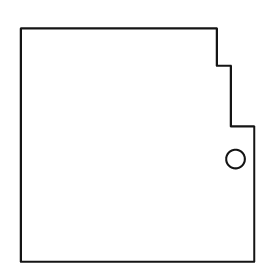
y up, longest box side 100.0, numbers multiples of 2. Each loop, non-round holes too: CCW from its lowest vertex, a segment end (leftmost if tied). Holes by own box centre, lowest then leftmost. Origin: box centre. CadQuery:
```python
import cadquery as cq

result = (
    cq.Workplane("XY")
    .moveTo(-50.0, -50.0)
    .lineTo(50.0, -50.0)
    .lineTo(50.0, 8.0)
    .lineTo(40.0, 8.0)
    .lineTo(40.0, 34.0)
    .lineTo(34.0, 34.0)
    .lineTo(34.0, 50.0)
    .lineTo(-50.0, 50.0)
    .close()
    .moveTo(42.0, -6.0)
    .circle(4.0)
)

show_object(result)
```